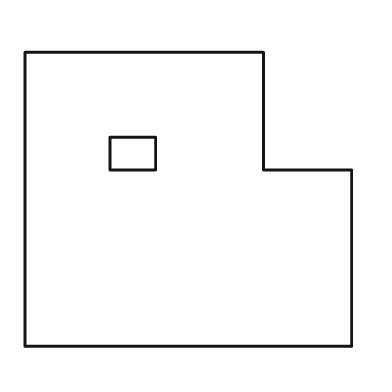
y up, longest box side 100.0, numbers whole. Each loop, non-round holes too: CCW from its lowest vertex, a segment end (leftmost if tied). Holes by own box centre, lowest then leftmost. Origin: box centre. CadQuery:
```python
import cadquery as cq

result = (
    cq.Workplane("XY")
    .moveTo(-50.0, -45.0)
    .lineTo(50.0, -45.0)
    .lineTo(50.0, 9.0)
    .lineTo(23.0, 9.0)
    .lineTo(23.0, 45.0)
    .lineTo(-50.0, 45.0)
    .close()
    .moveTo(-24.0, 9.0)
    .lineTo(-10.0, 9.0)
    .lineTo(-10.0, 19.0)
    .lineTo(-24.0, 19.0)
    .close()
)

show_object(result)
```